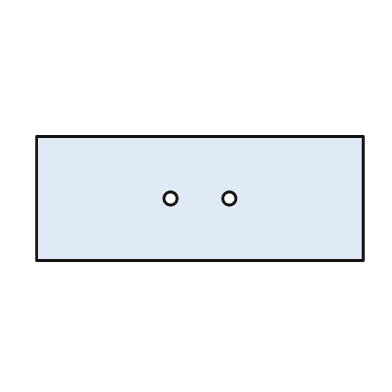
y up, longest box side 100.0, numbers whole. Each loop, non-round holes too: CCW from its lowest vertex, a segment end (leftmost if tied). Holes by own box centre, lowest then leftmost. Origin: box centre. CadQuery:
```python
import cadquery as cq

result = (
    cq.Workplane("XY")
    .moveTo(-50.0, -19.0)
    .lineTo(50.0, -19.0)
    .lineTo(50.0, 19.0)
    .lineTo(-50.0, 19.0)
    .close()
    .moveTo(-9.0, 0.0)
    .circle(2.0)
    .moveTo(9.0, 0.0)
    .circle(2.0)
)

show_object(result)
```